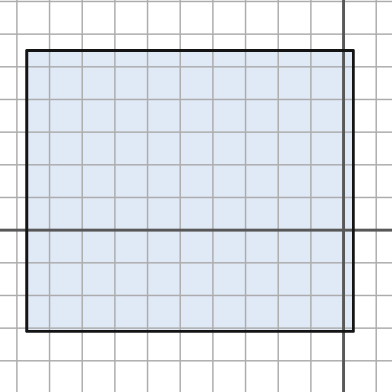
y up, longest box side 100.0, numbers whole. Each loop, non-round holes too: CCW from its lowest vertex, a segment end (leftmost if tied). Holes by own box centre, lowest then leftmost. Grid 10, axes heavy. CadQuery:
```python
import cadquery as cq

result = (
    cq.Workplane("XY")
    .moveTo(-97.0, -31.0)
    .lineTo(3.0, -31.0)
    .lineTo(3.0, 55.0)
    .lineTo(-97.0, 55.0)
    .close()
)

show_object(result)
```